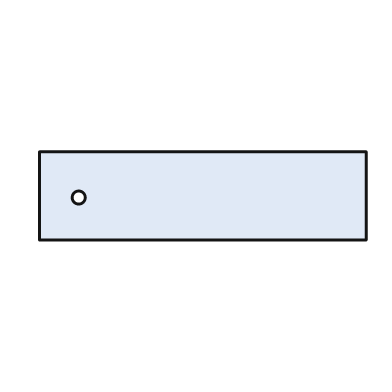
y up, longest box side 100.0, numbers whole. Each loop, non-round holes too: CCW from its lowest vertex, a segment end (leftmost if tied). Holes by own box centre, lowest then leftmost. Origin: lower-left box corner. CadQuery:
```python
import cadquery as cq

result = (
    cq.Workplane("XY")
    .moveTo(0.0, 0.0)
    .lineTo(100.0, 0.0)
    .lineTo(100.0, 27.0)
    .lineTo(0.0, 27.0)
    .close()
    .moveTo(12.0, 13.0)
    .circle(2.0)
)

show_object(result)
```